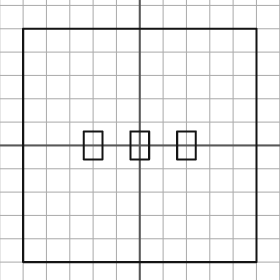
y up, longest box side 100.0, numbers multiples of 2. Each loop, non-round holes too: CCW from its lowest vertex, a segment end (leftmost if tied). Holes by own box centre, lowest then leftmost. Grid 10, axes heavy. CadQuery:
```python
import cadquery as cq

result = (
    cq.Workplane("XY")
    .moveTo(-50.0, -50.0)
    .lineTo(50.0, -50.0)
    .lineTo(50.0, 50.0)
    .lineTo(-50.0, 50.0)
    .close()
    .moveTo(-24.0, -6.0)
    .lineTo(-16.0, -6.0)
    .lineTo(-16.0, 6.0)
    .lineTo(-24.0, 6.0)
    .close()
    .moveTo(-4.0, -6.0)
    .lineTo(4.0, -6.0)
    .lineTo(4.0, 6.0)
    .lineTo(-4.0, 6.0)
    .close()
    .moveTo(16.0, -6.0)
    .lineTo(24.0, -6.0)
    .lineTo(24.0, 6.0)
    .lineTo(16.0, 6.0)
    .close()
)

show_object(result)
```